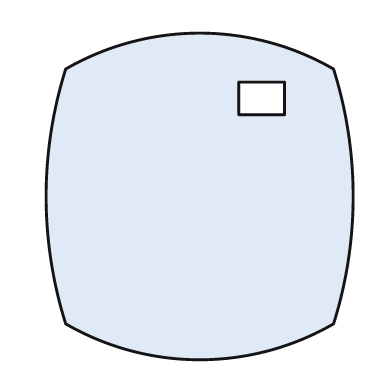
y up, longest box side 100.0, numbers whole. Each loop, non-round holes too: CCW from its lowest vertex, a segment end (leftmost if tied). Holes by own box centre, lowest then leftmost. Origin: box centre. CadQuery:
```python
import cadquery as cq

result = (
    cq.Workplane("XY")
    .moveTo(-41.0, -39.0)
    .threePointArc((0.0, -50.0), (41.0, -39.0))
    .threePointArc((47.0, 0.0), (41.0, 39.0))
    .threePointArc((0.0, 50.0), (-41.0, 39.0))
    .threePointArc((-47.0, 0.0), (-41.0, -39.0))
    .close()
    .moveTo(12.0, 25.0)
    .lineTo(26.0, 25.0)
    .lineTo(26.0, 35.0)
    .lineTo(12.0, 35.0)
    .close()
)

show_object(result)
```